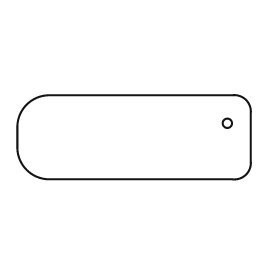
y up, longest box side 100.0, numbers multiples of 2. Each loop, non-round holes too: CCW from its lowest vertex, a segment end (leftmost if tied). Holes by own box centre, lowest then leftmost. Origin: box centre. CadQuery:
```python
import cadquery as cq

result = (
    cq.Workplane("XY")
    .moveTo(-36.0, -18.0)
    .lineTo(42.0, -18.0)
    .threePointArc((48.0, -16.0), (50.0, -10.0))
    .lineTo(50.0, 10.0)
    .threePointArc((48.0, 16.0), (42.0, 18.0))
    .lineTo(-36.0, 18.0)
    .threePointArc((-46.0, 14.0), (-50.0, 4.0))
    .lineTo(-50.0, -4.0)
    .threePointArc((-46.0, -14.0), (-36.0, -18.0))
    .close()
    .moveTo(40.0, 6.0)
    .circle(2.0)
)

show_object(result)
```